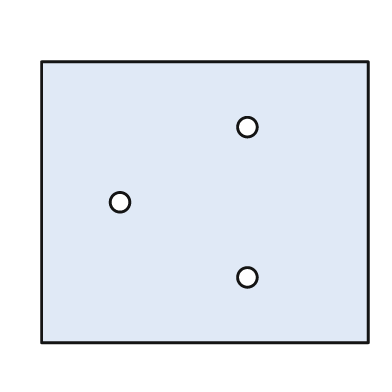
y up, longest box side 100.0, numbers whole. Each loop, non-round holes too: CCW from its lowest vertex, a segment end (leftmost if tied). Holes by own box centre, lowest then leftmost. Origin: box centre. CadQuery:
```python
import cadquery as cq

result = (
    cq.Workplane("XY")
    .moveTo(-50.0, -43.0)
    .lineTo(50.0, -43.0)
    .lineTo(50.0, 43.0)
    .lineTo(-50.0, 43.0)
    .close()
    .moveTo(13.0, -23.0)
    .circle(3.0)
    .moveTo(-26.0, 0.0)
    .circle(3.0)
    .moveTo(13.0, 23.0)
    .circle(3.0)
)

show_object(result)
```